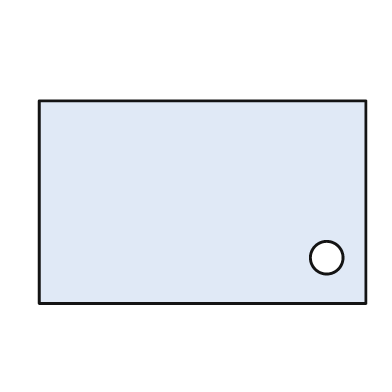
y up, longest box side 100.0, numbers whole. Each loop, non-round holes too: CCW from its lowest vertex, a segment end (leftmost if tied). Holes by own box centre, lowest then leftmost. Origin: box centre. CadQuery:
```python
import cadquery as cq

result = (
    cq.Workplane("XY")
    .moveTo(-50.0, -31.0)
    .lineTo(50.0, -31.0)
    .lineTo(50.0, 31.0)
    .lineTo(-50.0, 31.0)
    .close()
    .moveTo(38.0, -17.0)
    .circle(5.0)
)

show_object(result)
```